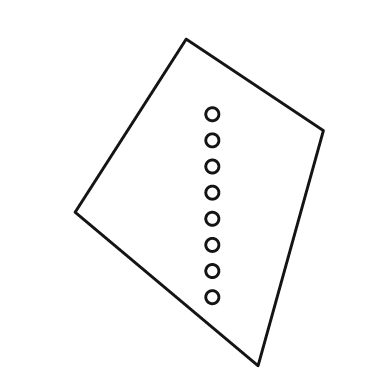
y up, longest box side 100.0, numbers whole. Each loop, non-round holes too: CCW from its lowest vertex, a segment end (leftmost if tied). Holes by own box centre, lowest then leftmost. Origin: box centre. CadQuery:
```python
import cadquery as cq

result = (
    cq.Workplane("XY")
    .moveTo(18.0, -50.0)
    .lineTo(38.0, 22.0)
    .lineTo(-4.0, 50.0)
    .lineTo(-38.0, -3.0)
    .close()
    .moveTo(4.0, -29.0)
    .circle(2.0)
    .moveTo(4.0, -21.0)
    .circle(2.0)
    .moveTo(4.0, -13.0)
    .circle(2.0)
    .moveTo(4.0, -5.0)
    .circle(2.0)
    .moveTo(4.0, 3.0)
    .circle(2.0)
    .moveTo(4.0, 11.0)
    .circle(2.0)
    .moveTo(4.0, 19.0)
    .circle(2.0)
    .moveTo(4.0, 27.0)
    .circle(2.0)
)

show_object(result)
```